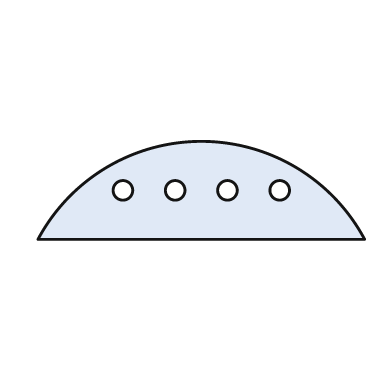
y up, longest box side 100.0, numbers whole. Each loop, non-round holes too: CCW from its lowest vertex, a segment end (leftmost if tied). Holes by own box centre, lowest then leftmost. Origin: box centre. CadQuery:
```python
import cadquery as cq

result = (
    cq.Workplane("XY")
    .moveTo(-50.0, -15.0)
    .lineTo(50.0, -15.0)
    .threePointArc((0.0, 15.0), (-50.0, -15.0))
    .close()
    .moveTo(-24.0, 0.0)
    .circle(3.0)
    .moveTo(-8.0, 0.0)
    .circle(3.0)
    .moveTo(8.0, 0.0)
    .circle(3.0)
    .moveTo(24.0, 0.0)
    .circle(3.0)
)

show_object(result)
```